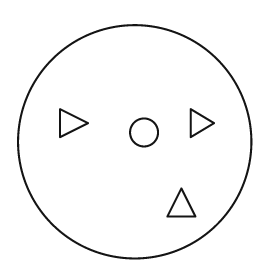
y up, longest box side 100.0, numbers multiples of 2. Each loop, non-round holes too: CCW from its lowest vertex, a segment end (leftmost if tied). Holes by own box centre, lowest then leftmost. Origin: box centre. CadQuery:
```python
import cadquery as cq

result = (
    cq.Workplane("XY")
    .moveTo(0.0, 0.0)
    .circle(50.0)
    .moveTo(14.0, -32.0)
    .lineTo(26.0, -32.0)
    .lineTo(20.0, -20.0)
    .close()
    .moveTo(4.0, 4.0)
    .circle(6.0)
    .moveTo(-32.0, 2.0)
    .lineTo(-20.0, 8.0)
    .lineTo(-32.0, 14.0)
    .close()
    .moveTo(24.0, 2.0)
    .lineTo(34.0, 8.0)
    .lineTo(24.0, 14.0)
    .close()
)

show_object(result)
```